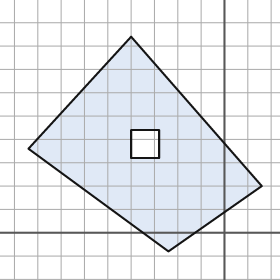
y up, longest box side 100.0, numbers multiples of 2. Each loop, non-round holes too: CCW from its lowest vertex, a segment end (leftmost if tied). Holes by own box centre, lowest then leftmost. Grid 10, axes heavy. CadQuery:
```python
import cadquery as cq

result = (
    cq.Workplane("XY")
    .moveTo(-24.0, -8.0)
    .lineTo(16.0, 20.0)
    .lineTo(-40.0, 84.0)
    .lineTo(-84.0, 36.0)
    .close()
    .moveTo(-40.0, 32.0)
    .lineTo(-28.0, 32.0)
    .lineTo(-28.0, 44.0)
    .lineTo(-40.0, 44.0)
    .close()
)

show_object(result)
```